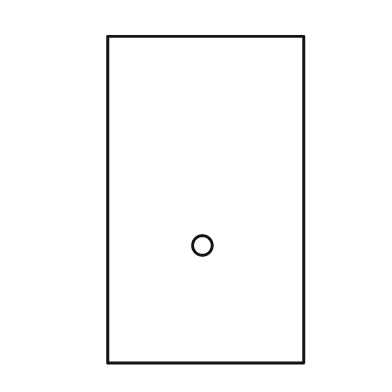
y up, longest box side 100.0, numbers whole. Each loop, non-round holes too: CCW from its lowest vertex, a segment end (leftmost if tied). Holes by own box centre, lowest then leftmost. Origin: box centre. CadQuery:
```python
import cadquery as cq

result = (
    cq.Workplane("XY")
    .moveTo(-30.0, -50.0)
    .lineTo(30.0, -50.0)
    .lineTo(30.0, 50.0)
    .lineTo(-30.0, 50.0)
    .close()
    .moveTo(-1.0, -14.0)
    .circle(3.0)
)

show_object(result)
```